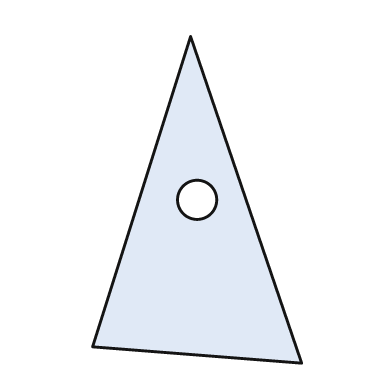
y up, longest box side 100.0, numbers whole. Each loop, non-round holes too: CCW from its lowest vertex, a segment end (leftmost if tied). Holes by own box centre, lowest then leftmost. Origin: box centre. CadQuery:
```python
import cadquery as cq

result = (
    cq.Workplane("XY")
    .moveTo(32.0, -50.0)
    .lineTo(-2.0, 50.0)
    .lineTo(-32.0, -45.0)
    .close()
    .moveTo(0.0, 0.0)
    .circle(6.0)
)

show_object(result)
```